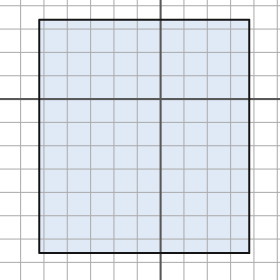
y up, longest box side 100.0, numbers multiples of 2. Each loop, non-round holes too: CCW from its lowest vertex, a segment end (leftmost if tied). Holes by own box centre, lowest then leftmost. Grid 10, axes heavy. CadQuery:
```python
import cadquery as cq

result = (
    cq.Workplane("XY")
    .moveTo(-52.0, -66.0)
    .lineTo(38.0, -66.0)
    .lineTo(38.0, 34.0)
    .lineTo(-52.0, 34.0)
    .close()
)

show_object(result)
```